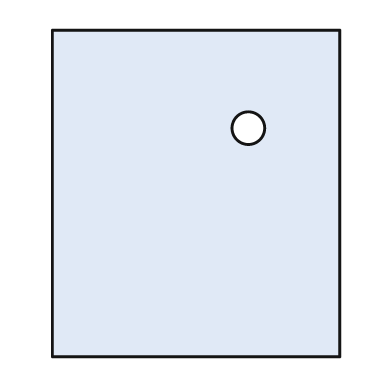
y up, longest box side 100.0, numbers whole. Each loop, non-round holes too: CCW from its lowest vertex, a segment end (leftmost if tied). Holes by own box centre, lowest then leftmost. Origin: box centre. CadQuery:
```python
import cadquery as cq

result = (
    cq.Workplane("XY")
    .moveTo(-44.0, -50.0)
    .lineTo(44.0, -50.0)
    .lineTo(44.0, 50.0)
    .lineTo(-44.0, 50.0)
    .close()
    .moveTo(16.0, 20.0)
    .circle(5.0)
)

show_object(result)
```